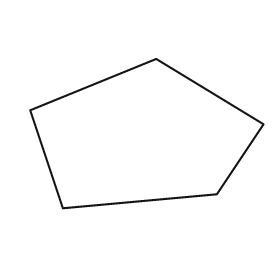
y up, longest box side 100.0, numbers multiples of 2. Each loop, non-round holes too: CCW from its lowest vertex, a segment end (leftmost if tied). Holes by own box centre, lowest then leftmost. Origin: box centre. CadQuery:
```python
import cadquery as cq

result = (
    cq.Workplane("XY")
    .moveTo(-36.0, -32.0)
    .lineTo(30.0, -26.0)
    .lineTo(50.0, 4.0)
    .lineTo(4.0, 32.0)
    .lineTo(-50.0, 10.0)
    .close()
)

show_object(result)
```